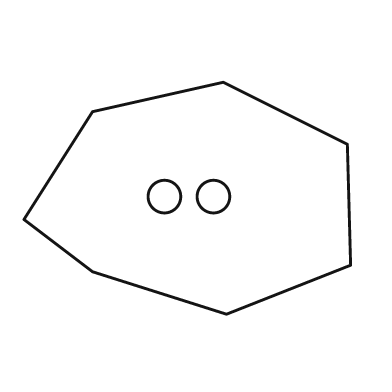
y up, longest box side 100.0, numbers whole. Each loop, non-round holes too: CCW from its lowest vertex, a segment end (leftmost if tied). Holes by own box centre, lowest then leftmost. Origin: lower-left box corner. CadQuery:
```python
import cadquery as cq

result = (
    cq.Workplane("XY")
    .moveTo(62.0, 0.0)
    .lineTo(100.0, 15.0)
    .lineTo(99.0, 52.0)
    .lineTo(61.0, 71.0)
    .lineTo(21.0, 62.0)
    .lineTo(0.0, 29.0)
    .lineTo(21.0, 13.0)
    .close()
    .moveTo(43.0, 36.0)
    .circle(5.0)
    .moveTo(58.0, 36.0)
    .circle(5.0)
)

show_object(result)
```